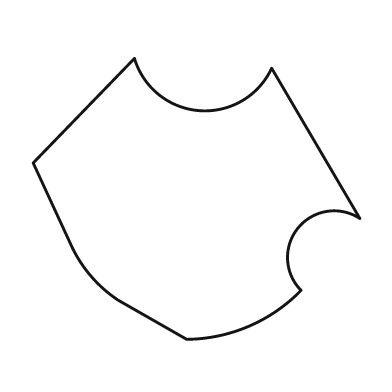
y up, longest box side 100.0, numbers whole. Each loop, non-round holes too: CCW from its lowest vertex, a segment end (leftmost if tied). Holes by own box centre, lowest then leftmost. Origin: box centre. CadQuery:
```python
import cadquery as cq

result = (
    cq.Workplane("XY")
    .moveTo(-3.0, -43.0)
    .threePointArc((16.0, -39.0), (32.0, -28.0))
    .threePointArc((31.0, -9.0), (50.0, -6.0))
    .lineTo(23.0, 40.0)
    .threePointArc((1.0, 27.0), (-19.0, 43.0))
    .lineTo(-50.0, 11.0)
    .lineTo(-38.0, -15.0)
    .threePointArc((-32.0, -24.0), (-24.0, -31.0))
    .close()
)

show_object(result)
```